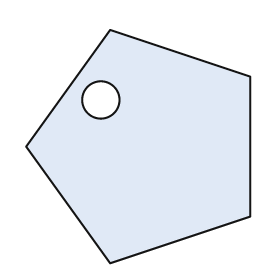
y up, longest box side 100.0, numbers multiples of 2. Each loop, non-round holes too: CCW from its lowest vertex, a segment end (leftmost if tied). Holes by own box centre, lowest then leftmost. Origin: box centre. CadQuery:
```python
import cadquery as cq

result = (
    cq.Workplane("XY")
    .moveTo(-12.0, -50.0)
    .lineTo(48.0, -30.0)
    .lineTo(48.0, 30.0)
    .lineTo(-12.0, 50.0)
    .lineTo(-48.0, 0.0)
    .close()
    .moveTo(-16.0, 20.0)
    .circle(8.0)
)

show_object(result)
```